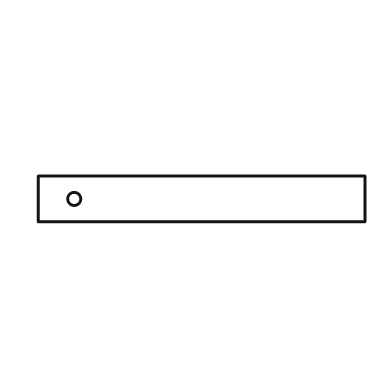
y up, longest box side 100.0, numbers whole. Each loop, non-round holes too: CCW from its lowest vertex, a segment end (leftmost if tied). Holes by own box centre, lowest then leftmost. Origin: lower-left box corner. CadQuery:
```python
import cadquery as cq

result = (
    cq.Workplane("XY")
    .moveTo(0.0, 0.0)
    .lineTo(100.0, 0.0)
    .lineTo(100.0, 14.0)
    .lineTo(0.0, 14.0)
    .close()
    .moveTo(11.0, 7.0)
    .circle(2.0)
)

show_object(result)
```